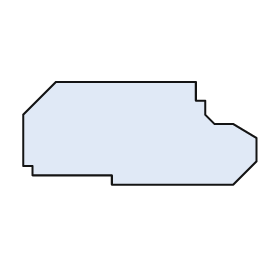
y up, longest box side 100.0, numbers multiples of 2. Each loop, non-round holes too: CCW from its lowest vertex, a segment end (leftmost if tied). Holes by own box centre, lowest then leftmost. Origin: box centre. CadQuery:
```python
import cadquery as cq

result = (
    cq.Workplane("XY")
    .moveTo(-12.0, -22.0)
    .lineTo(40.0, -22.0)
    .lineTo(50.0, -12.0)
    .lineTo(50.0, -2.0)
    .lineTo(40.0, 4.0)
    .lineTo(32.0, 4.0)
    .lineTo(28.0, 8.0)
    .lineTo(28.0, 14.0)
    .lineTo(24.0, 14.0)
    .lineTo(24.0, 22.0)
    .lineTo(-36.0, 22.0)
    .lineTo(-50.0, 8.0)
    .lineTo(-50.0, -14.0)
    .lineTo(-46.0, -14.0)
    .lineTo(-46.0, -18.0)
    .lineTo(-12.0, -18.0)
    .close()
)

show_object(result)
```